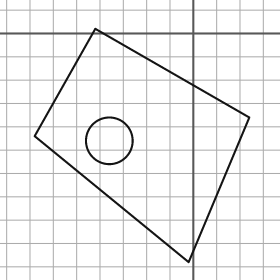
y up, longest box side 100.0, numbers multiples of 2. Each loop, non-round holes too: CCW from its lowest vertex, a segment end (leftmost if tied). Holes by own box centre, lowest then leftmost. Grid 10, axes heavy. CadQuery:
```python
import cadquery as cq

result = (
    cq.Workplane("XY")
    .moveTo(-2.0, -98.0)
    .lineTo(24.0, -36.0)
    .lineTo(-42.0, 2.0)
    .lineTo(-68.0, -44.0)
    .close()
    .moveTo(-36.0, -46.0)
    .circle(10.0)
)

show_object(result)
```